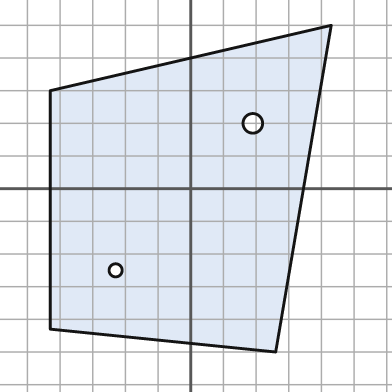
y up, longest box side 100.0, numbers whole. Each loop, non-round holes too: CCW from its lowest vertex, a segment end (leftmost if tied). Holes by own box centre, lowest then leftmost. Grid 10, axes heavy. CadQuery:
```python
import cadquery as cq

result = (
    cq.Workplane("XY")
    .moveTo(26.0, -50.0)
    .lineTo(43.0, 50.0)
    .lineTo(-43.0, 30.0)
    .lineTo(-43.0, -43.0)
    .close()
    .moveTo(-23.0, -25.0)
    .circle(2.0)
    .moveTo(19.0, 20.0)
    .circle(3.0)
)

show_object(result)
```